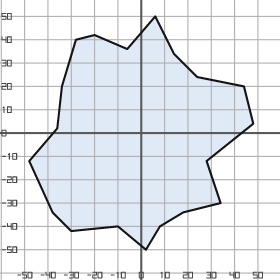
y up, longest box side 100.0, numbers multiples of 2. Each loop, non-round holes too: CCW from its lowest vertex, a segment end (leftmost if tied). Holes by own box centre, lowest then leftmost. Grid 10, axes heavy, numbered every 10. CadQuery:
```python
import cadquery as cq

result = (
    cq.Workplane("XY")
    .moveTo(2.0, -50.0)
    .lineTo(8.0, -40.0)
    .lineTo(18.0, -34.0)
    .lineTo(34.0, -30.0)
    .lineTo(28.0, -12.0)
    .lineTo(48.0, 4.0)
    .lineTo(44.0, 20.0)
    .lineTo(24.0, 24.0)
    .lineTo(14.0, 34.0)
    .lineTo(6.0, 50.0)
    .lineTo(-6.0, 36.0)
    .lineTo(-20.0, 42.0)
    .lineTo(-28.0, 40.0)
    .lineTo(-34.0, 20.0)
    .lineTo(-36.0, 2.0)
    .lineTo(-48.0, -12.0)
    .lineTo(-38.0, -34.0)
    .lineTo(-30.0, -42.0)
    .lineTo(-10.0, -40.0)
    .close()
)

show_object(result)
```